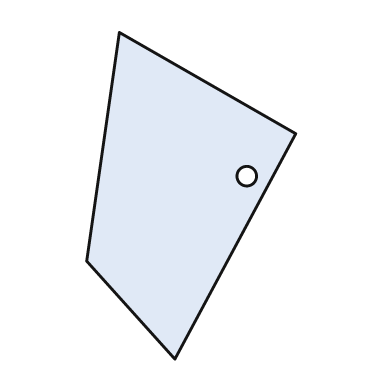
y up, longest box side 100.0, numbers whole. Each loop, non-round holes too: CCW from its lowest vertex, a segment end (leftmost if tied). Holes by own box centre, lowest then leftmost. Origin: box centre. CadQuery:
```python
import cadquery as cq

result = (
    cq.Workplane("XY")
    .moveTo(-5.0, -50.0)
    .lineTo(32.0, 19.0)
    .lineTo(-22.0, 50.0)
    .lineTo(-32.0, -20.0)
    .close()
    .moveTo(17.0, 6.0)
    .circle(3.0)
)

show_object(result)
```